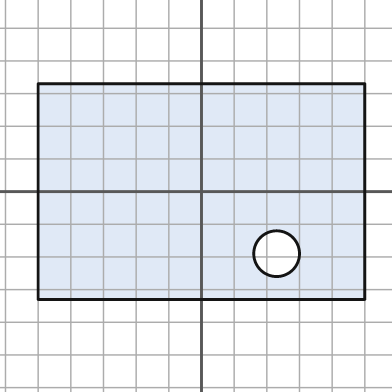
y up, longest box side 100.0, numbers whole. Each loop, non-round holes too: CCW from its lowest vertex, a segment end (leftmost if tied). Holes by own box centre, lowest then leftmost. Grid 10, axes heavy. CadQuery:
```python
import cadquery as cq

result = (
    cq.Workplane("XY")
    .moveTo(-50.0, -33.0)
    .lineTo(50.0, -33.0)
    .lineTo(50.0, 33.0)
    .lineTo(-50.0, 33.0)
    .close()
    .moveTo(23.0, -19.0)
    .circle(7.0)
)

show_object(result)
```